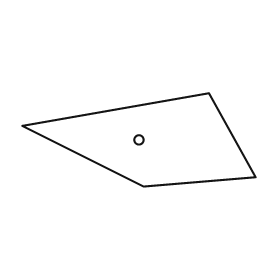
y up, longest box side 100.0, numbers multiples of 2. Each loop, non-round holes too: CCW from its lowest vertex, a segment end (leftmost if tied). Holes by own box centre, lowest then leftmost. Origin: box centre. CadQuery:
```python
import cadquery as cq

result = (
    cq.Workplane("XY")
    .moveTo(2.0, -20.0)
    .lineTo(50.0, -16.0)
    .lineTo(30.0, 20.0)
    .lineTo(-50.0, 6.0)
    .close()
    .moveTo(0.0, 0.0)
    .circle(2.0)
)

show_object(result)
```